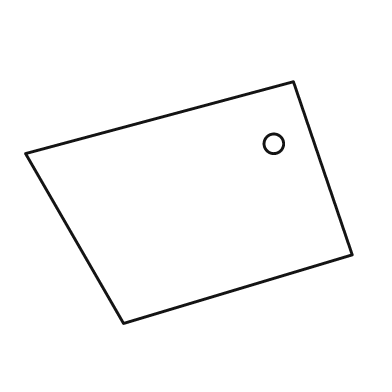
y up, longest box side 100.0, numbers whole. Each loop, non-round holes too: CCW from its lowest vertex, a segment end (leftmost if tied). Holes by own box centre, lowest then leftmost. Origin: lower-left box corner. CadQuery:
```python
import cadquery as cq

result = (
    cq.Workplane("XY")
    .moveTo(30.0, 0.0)
    .lineTo(100.0, 21.0)
    .lineTo(82.0, 74.0)
    .lineTo(0.0, 52.0)
    .close()
    .moveTo(76.0, 55.0)
    .circle(3.0)
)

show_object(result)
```